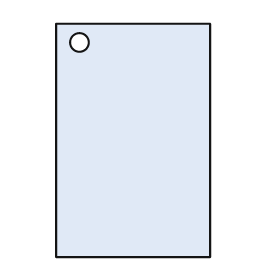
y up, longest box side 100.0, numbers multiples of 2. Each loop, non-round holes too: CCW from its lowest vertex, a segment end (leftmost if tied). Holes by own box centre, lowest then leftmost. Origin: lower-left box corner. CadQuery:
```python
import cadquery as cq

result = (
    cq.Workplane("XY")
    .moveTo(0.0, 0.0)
    .lineTo(66.0, 0.0)
    .lineTo(66.0, 100.0)
    .lineTo(0.0, 100.0)
    .close()
    .moveTo(10.0, 92.0)
    .circle(4.0)
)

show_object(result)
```